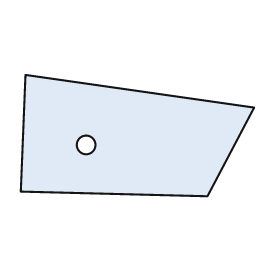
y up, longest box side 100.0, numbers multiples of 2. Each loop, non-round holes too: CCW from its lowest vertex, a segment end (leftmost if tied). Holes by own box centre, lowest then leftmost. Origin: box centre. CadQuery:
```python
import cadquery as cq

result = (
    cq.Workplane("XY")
    .moveTo(30.0, -26.0)
    .lineTo(50.0, 12.0)
    .lineTo(-48.0, 26.0)
    .lineTo(-50.0, -24.0)
    .close()
    .moveTo(-22.0, -4.0)
    .circle(4.0)
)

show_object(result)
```